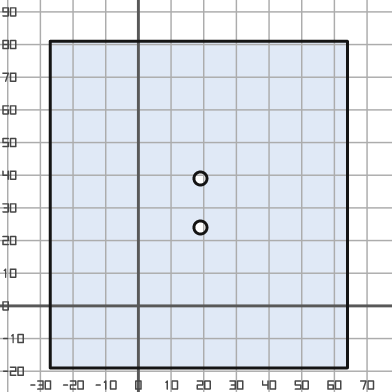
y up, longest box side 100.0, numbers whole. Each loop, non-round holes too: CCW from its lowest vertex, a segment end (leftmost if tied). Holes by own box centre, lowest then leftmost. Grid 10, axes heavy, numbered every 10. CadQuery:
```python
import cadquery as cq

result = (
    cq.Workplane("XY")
    .moveTo(-27.0, -19.0)
    .lineTo(64.0, -19.0)
    .lineTo(64.0, 81.0)
    .lineTo(-27.0, 81.0)
    .close()
    .moveTo(19.0, 24.0)
    .circle(2.0)
    .moveTo(19.0, 39.0)
    .circle(2.0)
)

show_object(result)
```